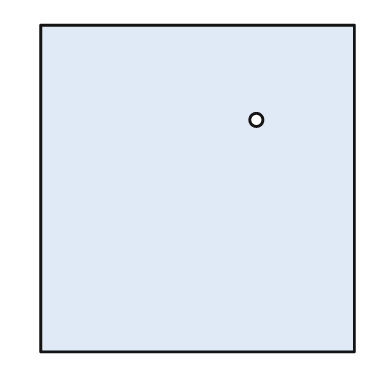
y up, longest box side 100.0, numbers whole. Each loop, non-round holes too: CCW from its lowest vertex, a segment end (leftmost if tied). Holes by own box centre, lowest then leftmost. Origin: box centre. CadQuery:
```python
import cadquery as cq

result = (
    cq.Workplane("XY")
    .moveTo(-48.0, -50.0)
    .lineTo(48.0, -50.0)
    .lineTo(48.0, 50.0)
    .lineTo(-48.0, 50.0)
    .close()
    .moveTo(18.0, 21.0)
    .circle(2.0)
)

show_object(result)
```